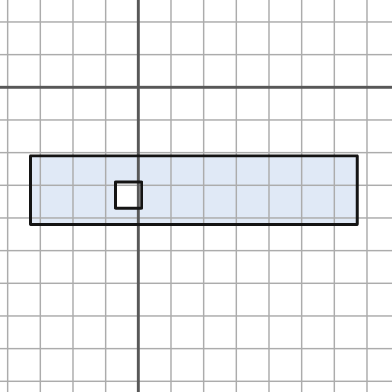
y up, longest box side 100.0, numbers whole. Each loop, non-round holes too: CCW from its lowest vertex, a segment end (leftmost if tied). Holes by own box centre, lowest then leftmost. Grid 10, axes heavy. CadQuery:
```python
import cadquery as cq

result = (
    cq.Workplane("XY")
    .moveTo(-33.0, -42.0)
    .lineTo(67.0, -42.0)
    .lineTo(67.0, -21.0)
    .lineTo(-33.0, -21.0)
    .close()
    .moveTo(-7.0, -37.0)
    .lineTo(1.0, -37.0)
    .lineTo(1.0, -29.0)
    .lineTo(-7.0, -29.0)
    .close()
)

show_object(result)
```